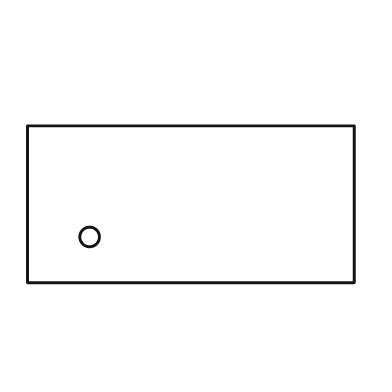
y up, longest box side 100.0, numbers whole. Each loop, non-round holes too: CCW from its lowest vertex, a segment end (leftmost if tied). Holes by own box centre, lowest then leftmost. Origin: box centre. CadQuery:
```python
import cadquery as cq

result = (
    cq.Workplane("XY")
    .moveTo(-50.0, -24.0)
    .lineTo(50.0, -24.0)
    .lineTo(50.0, 24.0)
    .lineTo(-50.0, 24.0)
    .close()
    .moveTo(-31.0, -10.0)
    .circle(3.0)
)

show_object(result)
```